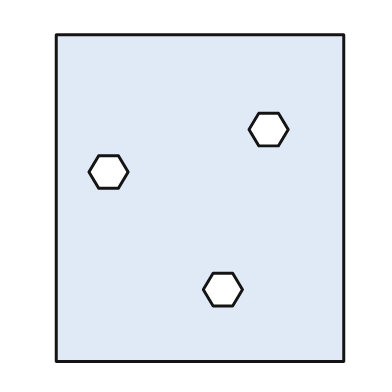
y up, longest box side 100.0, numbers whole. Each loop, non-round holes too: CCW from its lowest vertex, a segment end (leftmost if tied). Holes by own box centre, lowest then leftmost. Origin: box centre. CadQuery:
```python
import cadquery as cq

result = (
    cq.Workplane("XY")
    .moveTo(-44.0, -50.0)
    .lineTo(44.0, -50.0)
    .lineTo(44.0, 50.0)
    .lineTo(-44.0, 50.0)
    .close()
    .moveTo(4.0, -33.0)
    .lineTo(10.0, -33.0)
    .lineTo(13.0, -28.0)
    .lineTo(10.0, -23.0)
    .lineTo(4.0, -23.0)
    .lineTo(1.0, -28.0)
    .close()
    .moveTo(-31.0, 3.0)
    .lineTo(-25.0, 3.0)
    .lineTo(-22.0, 8.0)
    .lineTo(-25.0, 13.0)
    .lineTo(-31.0, 13.0)
    .lineTo(-34.0, 8.0)
    .close()
    .moveTo(18.0, 16.0)
    .lineTo(24.0, 16.0)
    .lineTo(27.0, 21.0)
    .lineTo(24.0, 26.0)
    .lineTo(18.0, 26.0)
    .lineTo(15.0, 21.0)
    .close()
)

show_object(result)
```